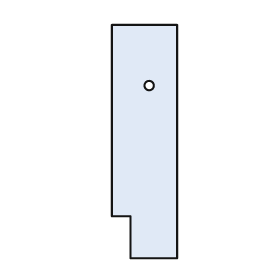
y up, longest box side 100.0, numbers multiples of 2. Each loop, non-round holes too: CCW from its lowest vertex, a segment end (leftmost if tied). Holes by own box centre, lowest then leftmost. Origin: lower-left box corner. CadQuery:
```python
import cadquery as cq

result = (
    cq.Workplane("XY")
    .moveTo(8.0, 0.0)
    .lineTo(28.0, 0.0)
    .lineTo(28.0, 100.0)
    .lineTo(0.0, 100.0)
    .lineTo(0.0, 18.0)
    .lineTo(8.0, 18.0)
    .close()
    .moveTo(16.0, 74.0)
    .circle(2.0)
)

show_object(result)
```